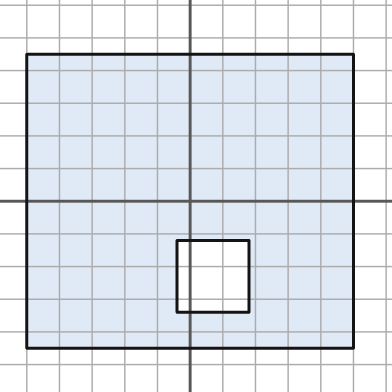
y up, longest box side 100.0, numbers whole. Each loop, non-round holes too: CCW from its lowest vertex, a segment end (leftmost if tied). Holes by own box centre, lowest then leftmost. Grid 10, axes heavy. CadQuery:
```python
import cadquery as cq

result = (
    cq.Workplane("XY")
    .moveTo(-50.0, -45.0)
    .lineTo(50.0, -45.0)
    .lineTo(50.0, 45.0)
    .lineTo(-50.0, 45.0)
    .close()
    .moveTo(-4.0, -34.0)
    .lineTo(18.0, -34.0)
    .lineTo(18.0, -12.0)
    .lineTo(-4.0, -12.0)
    .close()
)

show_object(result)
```